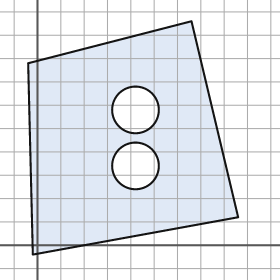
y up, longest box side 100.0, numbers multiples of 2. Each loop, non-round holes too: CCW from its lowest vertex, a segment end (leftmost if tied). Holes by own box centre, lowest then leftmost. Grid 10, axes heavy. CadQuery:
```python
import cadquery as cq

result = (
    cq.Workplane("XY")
    .moveTo(-2.0, -4.0)
    .lineTo(86.0, 12.0)
    .lineTo(66.0, 96.0)
    .lineTo(-4.0, 78.0)
    .close()
    .moveTo(42.0, 34.0)
    .circle(10.0)
    .moveTo(42.0, 58.0)
    .circle(10.0)
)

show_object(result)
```